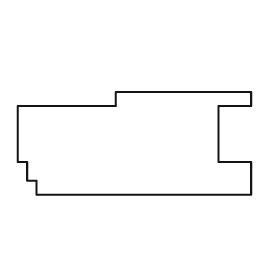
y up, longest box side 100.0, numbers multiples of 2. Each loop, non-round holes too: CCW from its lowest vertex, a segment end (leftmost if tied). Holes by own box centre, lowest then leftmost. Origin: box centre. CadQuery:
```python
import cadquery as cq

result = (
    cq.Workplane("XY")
    .moveTo(-42.0, -22.0)
    .lineTo(50.0, -22.0)
    .lineTo(50.0, -8.0)
    .lineTo(36.0, -8.0)
    .lineTo(36.0, 16.0)
    .lineTo(50.0, 16.0)
    .lineTo(50.0, 22.0)
    .lineTo(-8.0, 22.0)
    .lineTo(-8.0, 16.0)
    .lineTo(-50.0, 16.0)
    .lineTo(-50.0, -8.0)
    .lineTo(-46.0, -8.0)
    .lineTo(-46.0, -16.0)
    .lineTo(-42.0, -16.0)
    .close()
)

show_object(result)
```